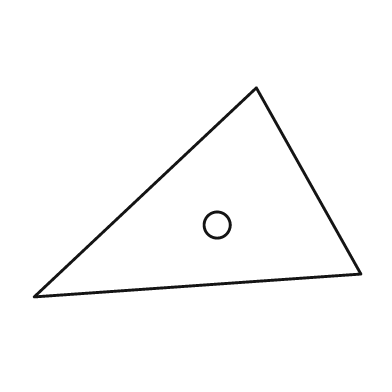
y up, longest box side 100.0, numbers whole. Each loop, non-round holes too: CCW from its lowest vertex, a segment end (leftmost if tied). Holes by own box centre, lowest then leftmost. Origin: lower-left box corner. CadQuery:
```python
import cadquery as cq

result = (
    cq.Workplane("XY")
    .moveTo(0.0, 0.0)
    .lineTo(100.0, 7.0)
    .lineTo(68.0, 64.0)
    .close()
    .moveTo(56.0, 22.0)
    .circle(4.0)
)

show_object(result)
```